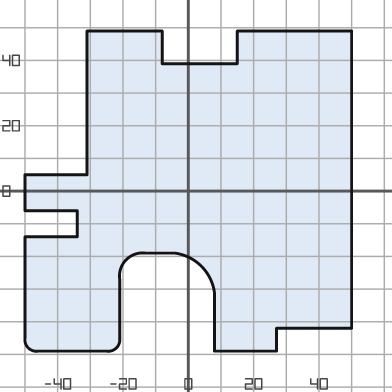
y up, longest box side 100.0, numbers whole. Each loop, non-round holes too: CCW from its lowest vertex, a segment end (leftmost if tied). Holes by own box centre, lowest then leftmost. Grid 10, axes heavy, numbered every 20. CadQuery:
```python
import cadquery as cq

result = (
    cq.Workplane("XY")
    .moveTo(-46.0, -49.0)
    .lineTo(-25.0, -49.0)
    .threePointArc((-22.0, -48.0), (-21.0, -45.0))
    .lineTo(-21.0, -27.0)
    .threePointArc((-19.0, -21.0), (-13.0, -19.0))
    .lineTo(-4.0, -19.0)
    .threePointArc((4.0, -23.0), (8.0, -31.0))
    .lineTo(8.0, -49.0)
    .lineTo(27.0, -49.0)
    .lineTo(27.0, -42.0)
    .lineTo(50.0, -42.0)
    .lineTo(50.0, 49.0)
    .lineTo(15.0, 49.0)
    .lineTo(15.0, 39.0)
    .lineTo(-8.0, 39.0)
    .lineTo(-8.0, 49.0)
    .lineTo(-31.0, 49.0)
    .lineTo(-31.0, 5.0)
    .lineTo(-50.0, 5.0)
    .lineTo(-50.0, -6.0)
    .lineTo(-34.0, -6.0)
    .lineTo(-34.0, -14.0)
    .lineTo(-50.0, -14.0)
    .lineTo(-50.0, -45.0)
    .threePointArc((-49.0, -48.0), (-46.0, -49.0))
    .close()
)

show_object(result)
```